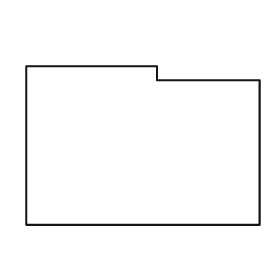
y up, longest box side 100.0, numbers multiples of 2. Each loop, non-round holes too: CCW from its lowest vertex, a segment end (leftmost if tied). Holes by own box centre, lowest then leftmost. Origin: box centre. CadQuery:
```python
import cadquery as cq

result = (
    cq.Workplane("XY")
    .moveTo(-50.0, -34.0)
    .lineTo(50.0, -34.0)
    .lineTo(50.0, 28.0)
    .lineTo(6.0, 28.0)
    .lineTo(6.0, 34.0)
    .lineTo(-50.0, 34.0)
    .close()
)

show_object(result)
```